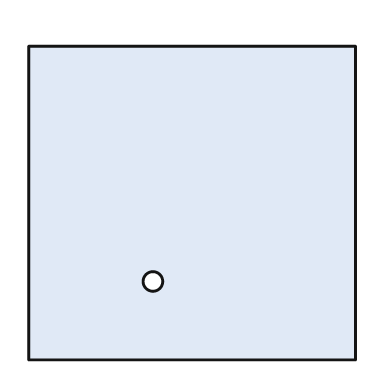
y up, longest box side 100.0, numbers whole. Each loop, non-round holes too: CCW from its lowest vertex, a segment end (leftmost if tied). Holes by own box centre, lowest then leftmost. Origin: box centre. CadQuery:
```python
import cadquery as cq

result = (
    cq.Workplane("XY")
    .moveTo(-50.0, -48.0)
    .lineTo(50.0, -48.0)
    .lineTo(50.0, 48.0)
    .lineTo(-50.0, 48.0)
    .close()
    .moveTo(-12.0, -24.0)
    .circle(3.0)
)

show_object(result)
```